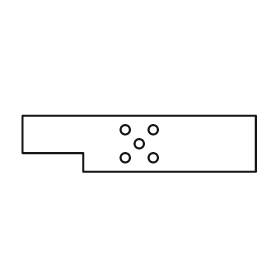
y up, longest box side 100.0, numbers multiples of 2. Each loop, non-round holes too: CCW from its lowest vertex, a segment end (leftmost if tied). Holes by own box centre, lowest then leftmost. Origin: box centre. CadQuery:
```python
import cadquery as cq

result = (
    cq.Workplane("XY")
    .moveTo(-24.0, -12.0)
    .lineTo(50.0, -12.0)
    .lineTo(50.0, 12.0)
    .lineTo(-50.0, 12.0)
    .lineTo(-50.0, -4.0)
    .lineTo(-24.0, -4.0)
    .close()
    .moveTo(-6.0, -6.0)
    .circle(2.0)
    .moveTo(6.0, -6.0)
    .circle(2.0)
    .moveTo(0.0, 0.0)
    .circle(2.0)
    .moveTo(-6.0, 6.0)
    .circle(2.0)
    .moveTo(6.0, 6.0)
    .circle(2.0)
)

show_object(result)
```